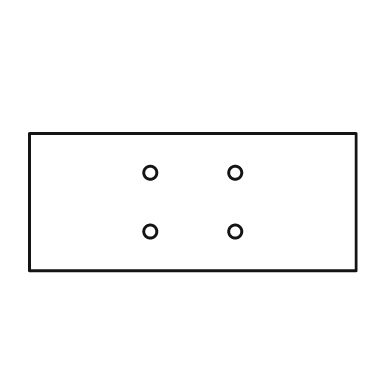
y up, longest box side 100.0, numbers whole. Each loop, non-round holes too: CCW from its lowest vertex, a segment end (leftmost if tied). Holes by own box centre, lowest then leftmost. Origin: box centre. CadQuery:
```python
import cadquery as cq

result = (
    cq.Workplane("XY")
    .moveTo(-50.0, -21.0)
    .lineTo(50.0, -21.0)
    .lineTo(50.0, 21.0)
    .lineTo(-50.0, 21.0)
    .close()
    .moveTo(-13.0, -9.0)
    .circle(2.0)
    .moveTo(13.0, -9.0)
    .circle(2.0)
    .moveTo(-13.0, 9.0)
    .circle(2.0)
    .moveTo(13.0, 9.0)
    .circle(2.0)
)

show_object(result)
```